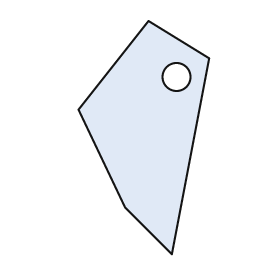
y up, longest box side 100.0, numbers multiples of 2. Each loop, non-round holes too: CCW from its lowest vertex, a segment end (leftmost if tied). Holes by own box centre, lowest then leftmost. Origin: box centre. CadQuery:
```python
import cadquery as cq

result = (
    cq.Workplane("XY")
    .moveTo(12.0, -50.0)
    .lineTo(28.0, 34.0)
    .lineTo(2.0, 50.0)
    .lineTo(-28.0, 12.0)
    .lineTo(-8.0, -30.0)
    .close()
    .moveTo(14.0, 26.0)
    .circle(6.0)
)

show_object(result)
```